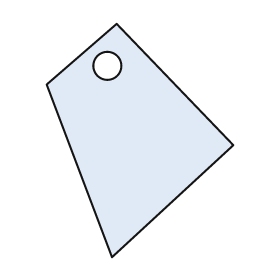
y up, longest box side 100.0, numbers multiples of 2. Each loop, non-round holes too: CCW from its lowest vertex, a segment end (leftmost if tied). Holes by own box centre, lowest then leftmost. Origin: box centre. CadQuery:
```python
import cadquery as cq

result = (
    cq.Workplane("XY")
    .moveTo(-12.0, -50.0)
    .lineTo(40.0, -2.0)
    .lineTo(-10.0, 50.0)
    .lineTo(-40.0, 24.0)
    .close()
    .moveTo(-14.0, 32.0)
    .circle(6.0)
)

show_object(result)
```